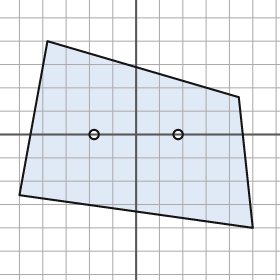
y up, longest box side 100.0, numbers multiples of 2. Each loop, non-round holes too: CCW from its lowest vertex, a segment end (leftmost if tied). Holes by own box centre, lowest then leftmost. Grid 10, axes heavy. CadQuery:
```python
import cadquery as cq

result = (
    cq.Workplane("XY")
    .moveTo(50.0, -40.0)
    .lineTo(44.0, 16.0)
    .lineTo(-38.0, 40.0)
    .lineTo(-50.0, -26.0)
    .close()
    .moveTo(-18.0, 0.0)
    .circle(2.0)
    .moveTo(18.0, 0.0)
    .circle(2.0)
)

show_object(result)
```